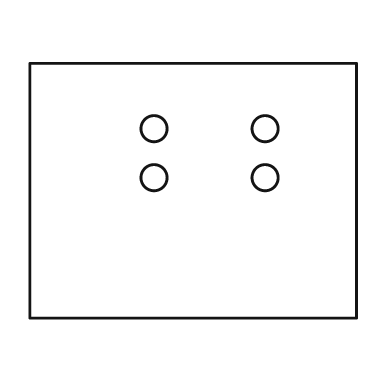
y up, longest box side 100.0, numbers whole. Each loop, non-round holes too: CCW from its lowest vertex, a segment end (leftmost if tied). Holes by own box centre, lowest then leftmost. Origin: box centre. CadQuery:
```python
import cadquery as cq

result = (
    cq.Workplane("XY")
    .moveTo(-50.0, -39.0)
    .lineTo(50.0, -39.0)
    .lineTo(50.0, 39.0)
    .lineTo(-50.0, 39.0)
    .close()
    .moveTo(-12.0, 4.0)
    .circle(4.0)
    .moveTo(22.0, 4.0)
    .circle(4.0)
    .moveTo(-12.0, 19.0)
    .circle(4.0)
    .moveTo(22.0, 19.0)
    .circle(4.0)
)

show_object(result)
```